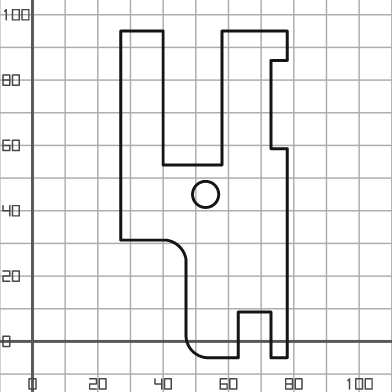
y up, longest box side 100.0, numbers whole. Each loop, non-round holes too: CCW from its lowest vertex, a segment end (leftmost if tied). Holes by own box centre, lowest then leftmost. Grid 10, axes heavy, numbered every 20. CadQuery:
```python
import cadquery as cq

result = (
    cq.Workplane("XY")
    .moveTo(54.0, -5.0)
    .lineTo(63.0, -5.0)
    .lineTo(63.0, 9.0)
    .lineTo(73.0, 9.0)
    .lineTo(73.0, -5.0)
    .lineTo(78.0, -5.0)
    .lineTo(78.0, 59.0)
    .lineTo(73.0, 59.0)
    .lineTo(73.0, 86.0)
    .lineTo(78.0, 86.0)
    .lineTo(78.0, 95.0)
    .lineTo(58.0, 95.0)
    .lineTo(58.0, 54.0)
    .lineTo(40.0, 54.0)
    .lineTo(40.0, 95.0)
    .lineTo(27.0, 95.0)
    .lineTo(27.0, 31.0)
    .lineTo(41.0, 31.0)
    .threePointArc((45.0, 29.0), (47.0, 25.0))
    .lineTo(47.0, 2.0)
    .threePointArc((49.0, -3.0), (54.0, -5.0))
    .close()
    .moveTo(53.0, 45.0)
    .circle(4.0)
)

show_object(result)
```